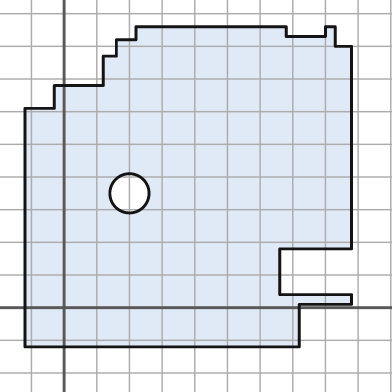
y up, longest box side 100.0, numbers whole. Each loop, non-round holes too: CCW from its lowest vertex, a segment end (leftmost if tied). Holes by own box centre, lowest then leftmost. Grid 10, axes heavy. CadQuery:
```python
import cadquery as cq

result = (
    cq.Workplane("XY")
    .moveTo(-12.0, -12.0)
    .lineTo(72.0, -12.0)
    .lineTo(72.0, 1.0)
    .lineTo(88.0, 1.0)
    .lineTo(88.0, 4.0)
    .lineTo(66.0, 4.0)
    .lineTo(66.0, 18.0)
    .lineTo(88.0, 18.0)
    .lineTo(88.0, 80.0)
    .lineTo(83.0, 80.0)
    .lineTo(83.0, 86.0)
    .lineTo(80.0, 86.0)
    .lineTo(80.0, 83.0)
    .lineTo(68.0, 83.0)
    .lineTo(68.0, 86.0)
    .lineTo(22.0, 86.0)
    .lineTo(22.0, 82.0)
    .lineTo(16.0, 82.0)
    .lineTo(16.0, 77.0)
    .lineTo(12.0, 77.0)
    .lineTo(12.0, 68.0)
    .lineTo(-3.0, 68.0)
    .lineTo(-3.0, 61.0)
    .lineTo(-12.0, 61.0)
    .close()
    .moveTo(20.0, 35.0)
    .circle(6.0)
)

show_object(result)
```